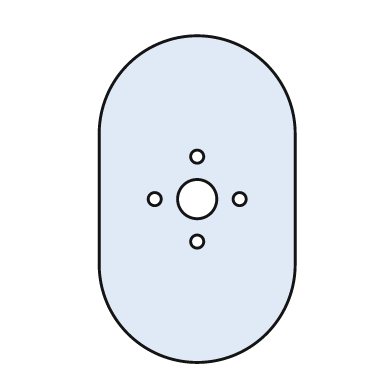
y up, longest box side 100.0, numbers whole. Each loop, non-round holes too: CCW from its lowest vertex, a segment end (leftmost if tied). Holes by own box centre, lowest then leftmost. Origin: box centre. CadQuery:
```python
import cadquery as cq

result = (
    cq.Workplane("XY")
    .moveTo(-30.0, -20.0)
    .threePointArc((0.0, -50.0), (30.0, -20.0))
    .lineTo(30.0, 20.0)
    .threePointArc((0.0, 50.0), (-30.0, 20.0))
    .close()
    .moveTo(0.0, -13.0)
    .circle(2.0)
    .moveTo(-13.0, 0.0)
    .circle(2.0)
    .moveTo(0.0, 0.0)
    .circle(6.0)
    .moveTo(13.0, 0.0)
    .circle(2.0)
    .moveTo(0.0, 13.0)
    .circle(2.0)
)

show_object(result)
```